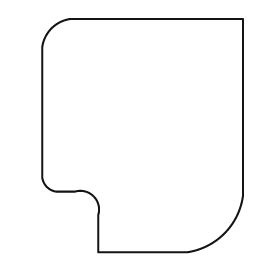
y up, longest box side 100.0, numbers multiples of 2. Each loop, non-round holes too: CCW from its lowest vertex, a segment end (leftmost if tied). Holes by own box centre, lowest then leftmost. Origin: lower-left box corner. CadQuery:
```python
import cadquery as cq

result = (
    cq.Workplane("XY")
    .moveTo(24.0, 0.0)
    .lineTo(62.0, 0.0)
    .threePointArc((78.0, 8.0), (86.0, 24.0))
    .lineTo(86.0, 100.0)
    .lineTo(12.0, 100.0)
    .threePointArc((4.0, 96.0), (0.0, 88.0))
    .lineTo(0.0, 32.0)
    .threePointArc((2.0, 28.0), (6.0, 26.0))
    .lineTo(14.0, 26.0)
    .threePointArc((22.0, 24.0), (24.0, 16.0))
    .close()
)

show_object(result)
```